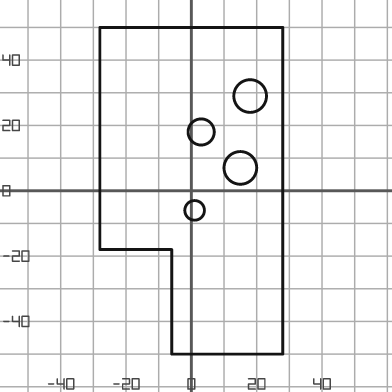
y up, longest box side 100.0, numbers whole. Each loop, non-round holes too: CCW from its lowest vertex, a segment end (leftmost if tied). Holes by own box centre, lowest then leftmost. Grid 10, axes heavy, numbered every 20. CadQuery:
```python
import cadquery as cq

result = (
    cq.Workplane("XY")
    .moveTo(-6.0, -50.0)
    .lineTo(28.0, -50.0)
    .lineTo(28.0, 50.0)
    .lineTo(-28.0, 50.0)
    .lineTo(-28.0, -18.0)
    .lineTo(-6.0, -18.0)
    .close()
    .moveTo(1.0, -6.0)
    .circle(3.0)
    .moveTo(15.0, 7.0)
    .circle(5.0)
    .moveTo(3.0, 18.0)
    .circle(4.0)
    .moveTo(18.0, 29.0)
    .circle(5.0)
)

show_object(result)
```